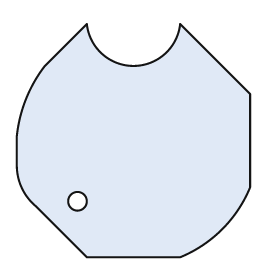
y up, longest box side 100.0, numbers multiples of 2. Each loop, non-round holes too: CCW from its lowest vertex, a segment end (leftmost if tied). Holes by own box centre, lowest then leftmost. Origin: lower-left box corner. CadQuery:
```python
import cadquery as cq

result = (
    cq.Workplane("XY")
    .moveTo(30.0, 0.0)
    .lineTo(70.0, 0.0)
    .threePointArc((88.0, 12.0), (100.0, 30.0))
    .lineTo(100.0, 70.0)
    .lineTo(70.0, 100.0)
    .threePointArc((50.0, 82.0), (30.0, 100.0))
    .lineTo(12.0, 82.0)
    .threePointArc((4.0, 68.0), (0.0, 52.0))
    .lineTo(0.0, 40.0)
    .threePointArc((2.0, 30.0), (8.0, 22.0))
    .close()
    .moveTo(26.0, 24.0)
    .circle(4.0)
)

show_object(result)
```